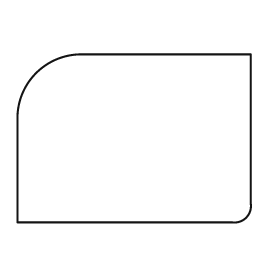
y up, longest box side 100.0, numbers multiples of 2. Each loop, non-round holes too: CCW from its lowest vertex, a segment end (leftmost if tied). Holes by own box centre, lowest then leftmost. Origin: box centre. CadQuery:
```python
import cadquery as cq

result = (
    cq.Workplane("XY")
    .moveTo(-50.0, -36.0)
    .lineTo(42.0, -36.0)
    .threePointArc((48.0, -34.0), (50.0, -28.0))
    .lineTo(50.0, 36.0)
    .lineTo(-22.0, 36.0)
    .threePointArc((-42.0, 28.0), (-50.0, 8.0))
    .close()
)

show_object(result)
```